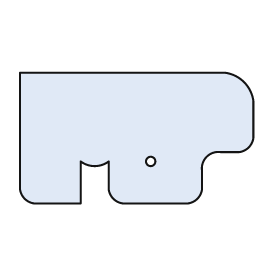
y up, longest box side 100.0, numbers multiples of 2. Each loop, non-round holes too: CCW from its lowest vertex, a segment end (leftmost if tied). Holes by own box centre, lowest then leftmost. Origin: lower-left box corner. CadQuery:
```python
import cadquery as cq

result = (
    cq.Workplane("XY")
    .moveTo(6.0, 0.0)
    .lineTo(26.0, 0.0)
    .lineTo(26.0, 18.0)
    .threePointArc((32.0, 16.0), (38.0, 18.0))
    .lineTo(38.0, 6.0)
    .threePointArc((40.0, 2.0), (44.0, 0.0))
    .lineTo(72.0, 0.0)
    .threePointArc((76.0, 2.0), (78.0, 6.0))
    .lineTo(78.0, 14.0)
    .threePointArc((80.0, 20.0), (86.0, 22.0))
    .lineTo(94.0, 22.0)
    .threePointArc((98.0, 24.0), (100.0, 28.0))
    .lineTo(100.0, 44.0)
    .threePointArc((96.0, 52.0), (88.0, 56.0))
    .lineTo(0.0, 56.0)
    .lineTo(0.0, 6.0)
    .threePointArc((2.0, 2.0), (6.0, 0.0))
    .close()
    .moveTo(56.0, 18.0)
    .circle(2.0)
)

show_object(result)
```